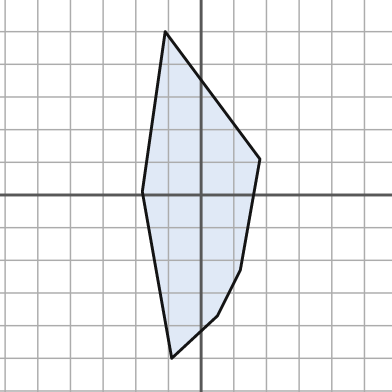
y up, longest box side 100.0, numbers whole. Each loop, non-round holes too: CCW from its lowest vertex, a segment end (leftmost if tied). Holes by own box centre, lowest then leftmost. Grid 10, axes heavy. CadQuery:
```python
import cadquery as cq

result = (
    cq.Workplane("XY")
    .moveTo(-9.0, -50.0)
    .lineTo(5.0, -37.0)
    .lineTo(12.0, -23.0)
    .lineTo(18.0, 11.0)
    .lineTo(-11.0, 50.0)
    .lineTo(-18.0, 1.0)
    .close()
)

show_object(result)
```